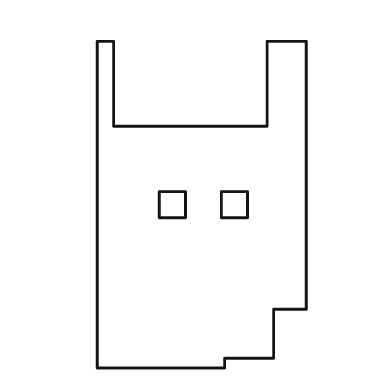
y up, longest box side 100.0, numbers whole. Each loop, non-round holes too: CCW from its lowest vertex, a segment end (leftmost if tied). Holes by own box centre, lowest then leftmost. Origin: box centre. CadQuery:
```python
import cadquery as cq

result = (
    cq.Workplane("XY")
    .moveTo(-32.0, -50.0)
    .lineTo(7.0, -50.0)
    .lineTo(7.0, -47.0)
    .lineTo(22.0, -47.0)
    .lineTo(22.0, -32.0)
    .lineTo(32.0, -32.0)
    .lineTo(32.0, 50.0)
    .lineTo(20.0, 50.0)
    .lineTo(20.0, 24.0)
    .lineTo(-27.0, 24.0)
    .lineTo(-27.0, 50.0)
    .lineTo(-32.0, 50.0)
    .close()
    .moveTo(-13.0, -4.0)
    .lineTo(-5.0, -4.0)
    .lineTo(-5.0, 4.0)
    .lineTo(-13.0, 4.0)
    .close()
    .moveTo(6.0, -4.0)
    .lineTo(14.0, -4.0)
    .lineTo(14.0, 4.0)
    .lineTo(6.0, 4.0)
    .close()
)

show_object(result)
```